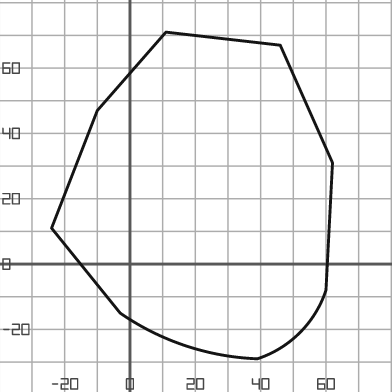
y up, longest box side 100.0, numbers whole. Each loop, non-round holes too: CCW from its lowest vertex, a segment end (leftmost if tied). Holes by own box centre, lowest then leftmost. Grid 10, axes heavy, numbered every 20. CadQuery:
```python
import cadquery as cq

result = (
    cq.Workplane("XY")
    .moveTo(39.0, -29.0)
    .threePointArc((52.0, -21.0), (60.0, -8.0))
    .lineTo(62.0, 31.0)
    .lineTo(46.0, 67.0)
    .lineTo(11.0, 71.0)
    .lineTo(-10.0, 47.0)
    .lineTo(-24.0, 11.0)
    .lineTo(-3.0, -15.0)
    .threePointArc((17.0, -25.0), (39.0, -29.0))
    .close()
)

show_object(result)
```